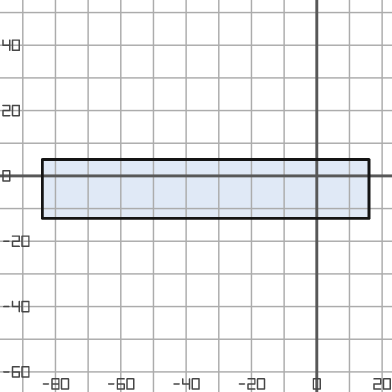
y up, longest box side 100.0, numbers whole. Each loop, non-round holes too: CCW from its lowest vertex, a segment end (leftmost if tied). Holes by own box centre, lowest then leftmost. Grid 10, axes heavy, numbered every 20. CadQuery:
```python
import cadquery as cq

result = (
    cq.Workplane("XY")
    .moveTo(-84.0, -13.0)
    .lineTo(16.0, -13.0)
    .lineTo(16.0, 5.0)
    .lineTo(-84.0, 5.0)
    .close()
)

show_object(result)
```